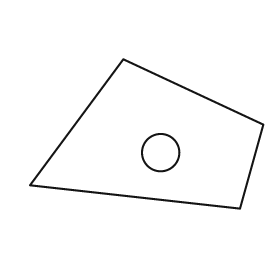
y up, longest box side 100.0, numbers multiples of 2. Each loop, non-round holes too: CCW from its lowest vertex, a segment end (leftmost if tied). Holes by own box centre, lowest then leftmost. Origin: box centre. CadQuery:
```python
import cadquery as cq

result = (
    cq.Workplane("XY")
    .moveTo(40.0, -32.0)
    .lineTo(50.0, 4.0)
    .lineTo(-10.0, 32.0)
    .lineTo(-50.0, -22.0)
    .close()
    .moveTo(6.0, -8.0)
    .circle(8.0)
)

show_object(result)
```